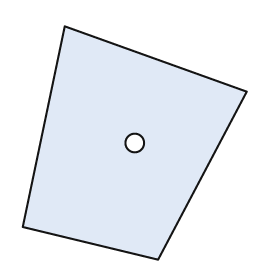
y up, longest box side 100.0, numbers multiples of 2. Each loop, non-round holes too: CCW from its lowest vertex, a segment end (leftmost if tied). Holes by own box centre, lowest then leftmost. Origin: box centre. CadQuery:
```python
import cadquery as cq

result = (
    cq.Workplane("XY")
    .moveTo(10.0, -50.0)
    .lineTo(48.0, 22.0)
    .lineTo(-30.0, 50.0)
    .lineTo(-48.0, -36.0)
    .close()
    .moveTo(0.0, 0.0)
    .circle(4.0)
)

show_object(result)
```